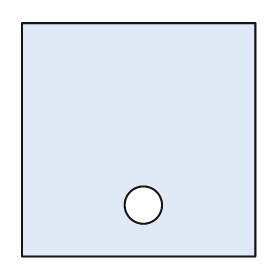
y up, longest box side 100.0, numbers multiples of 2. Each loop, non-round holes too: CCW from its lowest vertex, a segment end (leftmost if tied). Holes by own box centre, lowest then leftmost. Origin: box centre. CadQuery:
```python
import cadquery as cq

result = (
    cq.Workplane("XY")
    .moveTo(-50.0, -50.0)
    .lineTo(50.0, -50.0)
    .lineTo(50.0, 50.0)
    .lineTo(-50.0, 50.0)
    .close()
    .moveTo(2.0, -28.0)
    .circle(8.0)
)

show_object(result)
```